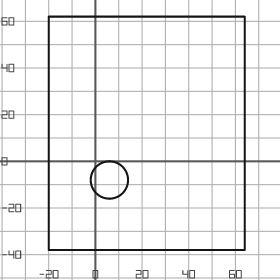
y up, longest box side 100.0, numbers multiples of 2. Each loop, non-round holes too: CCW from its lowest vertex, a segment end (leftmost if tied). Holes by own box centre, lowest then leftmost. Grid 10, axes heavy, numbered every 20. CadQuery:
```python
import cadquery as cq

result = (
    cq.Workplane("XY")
    .moveTo(-20.0, -38.0)
    .lineTo(64.0, -38.0)
    .lineTo(64.0, 62.0)
    .lineTo(-20.0, 62.0)
    .close()
    .moveTo(6.0, -8.0)
    .circle(8.0)
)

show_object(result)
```